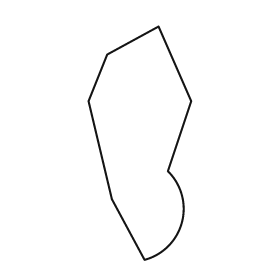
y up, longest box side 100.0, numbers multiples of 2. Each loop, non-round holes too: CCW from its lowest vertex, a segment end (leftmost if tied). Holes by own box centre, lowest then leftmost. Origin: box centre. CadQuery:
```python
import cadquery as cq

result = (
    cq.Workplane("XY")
    .moveTo(2.0, -50.0)
    .threePointArc((18.0, -34.0), (12.0, -12.0))
    .lineTo(22.0, 18.0)
    .lineTo(8.0, 50.0)
    .lineTo(-14.0, 38.0)
    .lineTo(-22.0, 18.0)
    .lineTo(-12.0, -24.0)
    .close()
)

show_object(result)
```